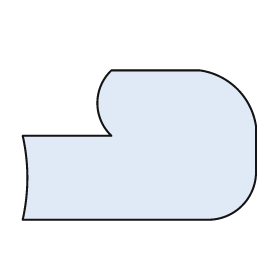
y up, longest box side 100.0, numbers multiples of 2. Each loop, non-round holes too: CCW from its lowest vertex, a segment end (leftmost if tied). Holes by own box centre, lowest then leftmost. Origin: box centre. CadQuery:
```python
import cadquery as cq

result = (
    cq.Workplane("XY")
    .moveTo(-50.0, -32.0)
    .lineTo(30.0, -32.0)
    .threePointArc((44.0, -26.0), (50.0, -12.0))
    .lineTo(50.0, 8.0)
    .threePointArc((42.0, 24.0), (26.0, 32.0))
    .lineTo(-12.0, 32.0)
    .threePointArc((-18.0, 18.0), (-12.0, 4.0))
    .lineTo(-50.0, 4.0)
    .threePointArc((-48.0, -14.0), (-50.0, -32.0))
    .close()
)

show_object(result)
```